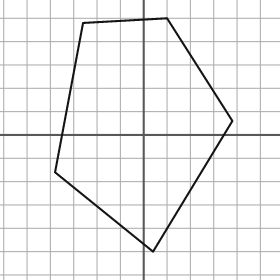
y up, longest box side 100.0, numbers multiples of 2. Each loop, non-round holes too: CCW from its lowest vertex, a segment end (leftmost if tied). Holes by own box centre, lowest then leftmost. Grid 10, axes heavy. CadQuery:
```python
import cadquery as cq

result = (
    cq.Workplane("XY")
    .moveTo(4.0, -50.0)
    .lineTo(38.0, 6.0)
    .lineTo(10.0, 50.0)
    .lineTo(-26.0, 48.0)
    .lineTo(-38.0, -16.0)
    .close()
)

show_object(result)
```